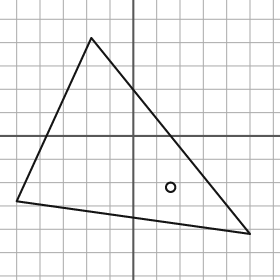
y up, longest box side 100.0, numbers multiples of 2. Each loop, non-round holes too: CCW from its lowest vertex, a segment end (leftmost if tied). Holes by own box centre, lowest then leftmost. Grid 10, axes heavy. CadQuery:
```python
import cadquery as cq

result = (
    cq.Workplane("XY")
    .moveTo(50.0, -42.0)
    .lineTo(-18.0, 42.0)
    .lineTo(-50.0, -28.0)
    .close()
    .moveTo(16.0, -22.0)
    .circle(2.0)
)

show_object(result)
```